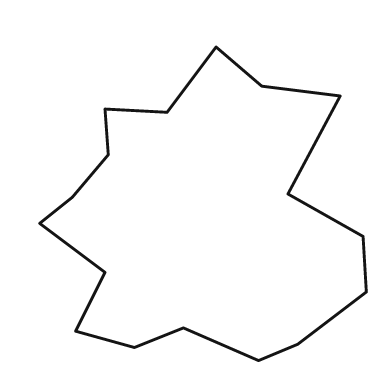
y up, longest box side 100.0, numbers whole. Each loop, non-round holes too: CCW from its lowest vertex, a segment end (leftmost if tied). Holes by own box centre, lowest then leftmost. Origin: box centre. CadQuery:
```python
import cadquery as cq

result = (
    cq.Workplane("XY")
    .moveTo(17.0, -48.0)
    .lineTo(29.0, -43.0)
    .lineTo(50.0, -27.0)
    .lineTo(49.0, -10.0)
    .lineTo(26.0, 3.0)
    .lineTo(42.0, 33.0)
    .lineTo(18.0, 36.0)
    .lineTo(4.0, 48.0)
    .lineTo(-11.0, 28.0)
    .lineTo(-30.0, 29.0)
    .lineTo(-29.0, 15.0)
    .lineTo(-40.0, 2.0)
    .lineTo(-50.0, -6.0)
    .lineTo(-30.0, -21.0)
    .lineTo(-39.0, -39.0)
    .lineTo(-21.0, -44.0)
    .lineTo(-6.0, -38.0)
    .close()
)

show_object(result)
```